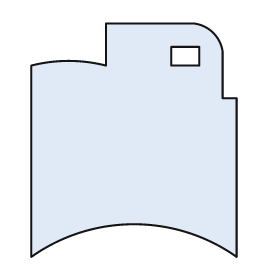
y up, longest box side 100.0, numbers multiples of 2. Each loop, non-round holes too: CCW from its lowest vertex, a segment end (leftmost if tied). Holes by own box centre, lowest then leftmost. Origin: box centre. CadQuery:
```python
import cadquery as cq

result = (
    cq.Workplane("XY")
    .moveTo(-44.0, -50.0)
    .threePointArc((0.0, -36.0), (44.0, -50.0))
    .lineTo(44.0, 18.0)
    .lineTo(38.0, 18.0)
    .lineTo(38.0, 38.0)
    .threePointArc((34.0, 46.0), (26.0, 50.0))
    .lineTo(-12.0, 50.0)
    .lineTo(-12.0, 32.0)
    .threePointArc((-28.0, 34.0), (-44.0, 32.0))
    .close()
    .moveTo(16.0, 32.0)
    .lineTo(28.0, 32.0)
    .lineTo(28.0, 40.0)
    .lineTo(16.0, 40.0)
    .close()
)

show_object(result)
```